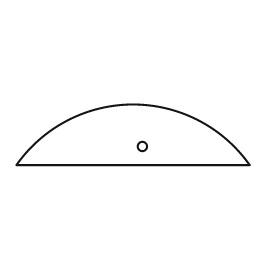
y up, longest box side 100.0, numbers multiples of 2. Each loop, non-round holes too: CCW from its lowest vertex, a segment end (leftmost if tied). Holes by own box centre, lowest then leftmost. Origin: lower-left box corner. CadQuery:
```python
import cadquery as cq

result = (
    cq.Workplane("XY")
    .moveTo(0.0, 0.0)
    .lineTo(100.0, 0.0)
    .threePointArc((50.0, 26.0), (0.0, 0.0))
    .close()
    .moveTo(54.0, 8.0)
    .circle(2.0)
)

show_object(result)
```